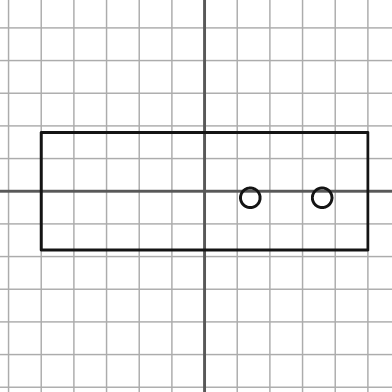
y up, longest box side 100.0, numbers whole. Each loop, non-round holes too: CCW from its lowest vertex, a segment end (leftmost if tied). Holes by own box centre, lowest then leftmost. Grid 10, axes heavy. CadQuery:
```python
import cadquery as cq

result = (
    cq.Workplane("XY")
    .moveTo(-50.0, -18.0)
    .lineTo(50.0, -18.0)
    .lineTo(50.0, 18.0)
    .lineTo(-50.0, 18.0)
    .close()
    .moveTo(14.0, -2.0)
    .circle(3.0)
    .moveTo(36.0, -2.0)
    .circle(3.0)
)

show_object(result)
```